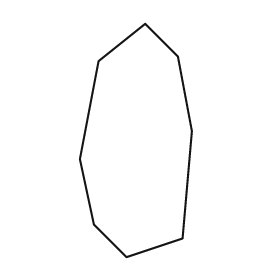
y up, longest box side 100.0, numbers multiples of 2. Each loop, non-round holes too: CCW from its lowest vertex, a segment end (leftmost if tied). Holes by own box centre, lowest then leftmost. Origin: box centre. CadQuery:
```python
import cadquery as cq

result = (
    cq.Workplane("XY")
    .moveTo(-4.0, -50.0)
    .lineTo(20.0, -42.0)
    .lineTo(24.0, 4.0)
    .lineTo(18.0, 36.0)
    .lineTo(4.0, 50.0)
    .lineTo(-16.0, 34.0)
    .lineTo(-24.0, -8.0)
    .lineTo(-18.0, -36.0)
    .close()
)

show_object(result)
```